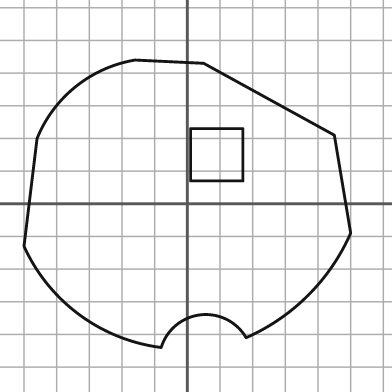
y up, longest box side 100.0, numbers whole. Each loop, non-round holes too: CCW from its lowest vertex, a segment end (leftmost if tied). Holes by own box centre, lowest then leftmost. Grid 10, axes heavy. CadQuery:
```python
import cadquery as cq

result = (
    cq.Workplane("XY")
    .moveTo(-8.0, -44.0)
    .threePointArc((4.0, -34.0), (18.0, -41.0))
    .threePointArc((37.0, -28.0), (50.0, -9.0))
    .lineTo(45.0, 21.0)
    .lineTo(5.0, 43.0)
    .lineTo(-16.0, 44.0)
    .threePointArc((-34.0, 36.0), (-46.0, 20.0))
    .lineTo(-50.0, -13.0)
    .threePointArc((-33.0, -34.0), (-8.0, -44.0))
    .close()
    .moveTo(1.0, 7.0)
    .lineTo(17.0, 7.0)
    .lineTo(17.0, 23.0)
    .lineTo(1.0, 23.0)
    .close()
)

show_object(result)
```